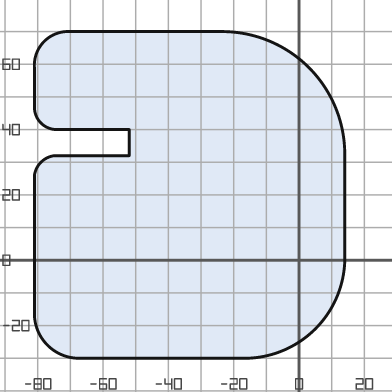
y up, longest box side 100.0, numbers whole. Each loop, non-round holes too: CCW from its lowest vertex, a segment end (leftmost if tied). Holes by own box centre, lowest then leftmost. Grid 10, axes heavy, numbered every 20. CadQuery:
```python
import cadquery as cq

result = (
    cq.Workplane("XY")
    .moveTo(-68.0, -30.0)
    .lineTo(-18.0, -30.0)
    .threePointArc((5.0, -21.0), (14.0, 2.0))
    .lineTo(14.0, 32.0)
    .threePointArc((3.0, 59.0), (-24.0, 70.0))
    .lineTo(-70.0, 70.0)
    .threePointArc((-78.0, 67.0), (-81.0, 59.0))
    .lineTo(-81.0, 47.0)
    .threePointArc((-79.0, 42.0), (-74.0, 40.0))
    .lineTo(-52.0, 40.0)
    .lineTo(-52.0, 32.0)
    .lineTo(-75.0, 32.0)
    .threePointArc((-79.0, 30.0), (-81.0, 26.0))
    .lineTo(-81.0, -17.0)
    .threePointArc((-77.0, -26.0), (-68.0, -30.0))
    .close()
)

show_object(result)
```